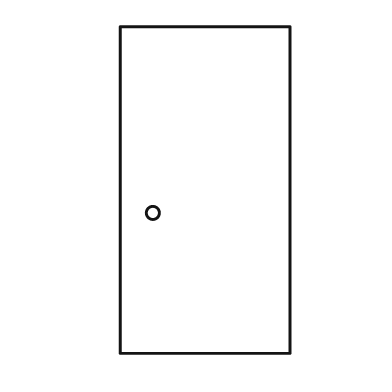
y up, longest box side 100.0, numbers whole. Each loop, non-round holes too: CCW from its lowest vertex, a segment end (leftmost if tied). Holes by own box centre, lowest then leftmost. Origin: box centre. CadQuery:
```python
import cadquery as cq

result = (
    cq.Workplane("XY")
    .moveTo(-26.0, -50.0)
    .lineTo(26.0, -50.0)
    .lineTo(26.0, 50.0)
    .lineTo(-26.0, 50.0)
    .close()
    .moveTo(-16.0, -7.0)
    .circle(2.0)
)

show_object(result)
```